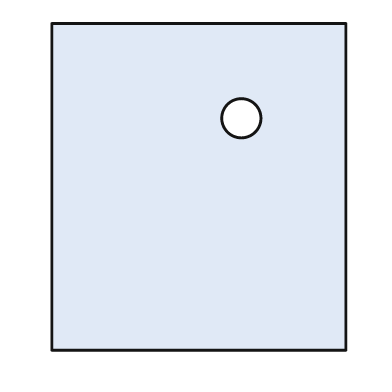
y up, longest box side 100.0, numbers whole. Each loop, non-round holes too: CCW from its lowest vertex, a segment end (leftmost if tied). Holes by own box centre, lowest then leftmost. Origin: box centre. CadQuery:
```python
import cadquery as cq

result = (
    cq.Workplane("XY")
    .moveTo(-45.0, -50.0)
    .lineTo(45.0, -50.0)
    .lineTo(45.0, 50.0)
    .lineTo(-45.0, 50.0)
    .close()
    .moveTo(13.0, 21.0)
    .circle(6.0)
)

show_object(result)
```